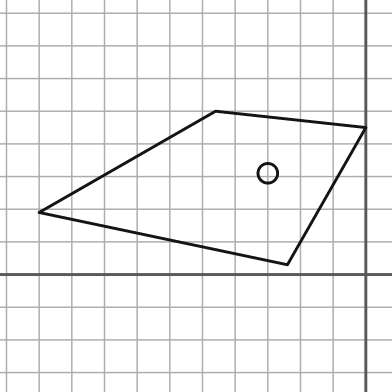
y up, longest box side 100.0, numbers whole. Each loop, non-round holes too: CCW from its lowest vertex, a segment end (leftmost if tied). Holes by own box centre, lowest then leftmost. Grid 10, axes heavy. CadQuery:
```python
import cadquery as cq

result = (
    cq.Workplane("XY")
    .moveTo(-24.0, 3.0)
    .lineTo(0.0, 45.0)
    .lineTo(-46.0, 50.0)
    .lineTo(-100.0, 19.0)
    .close()
    .moveTo(-30.0, 31.0)
    .circle(3.0)
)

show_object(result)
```